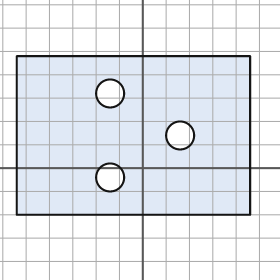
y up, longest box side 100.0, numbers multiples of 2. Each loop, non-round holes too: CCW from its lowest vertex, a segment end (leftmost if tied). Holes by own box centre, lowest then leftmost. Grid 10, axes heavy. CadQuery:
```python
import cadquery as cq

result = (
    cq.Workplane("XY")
    .moveTo(-54.0, -20.0)
    .lineTo(46.0, -20.0)
    .lineTo(46.0, 48.0)
    .lineTo(-54.0, 48.0)
    .close()
    .moveTo(-14.0, -4.0)
    .circle(6.0)
    .moveTo(16.0, 14.0)
    .circle(6.0)
    .moveTo(-14.0, 32.0)
    .circle(6.0)
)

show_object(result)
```